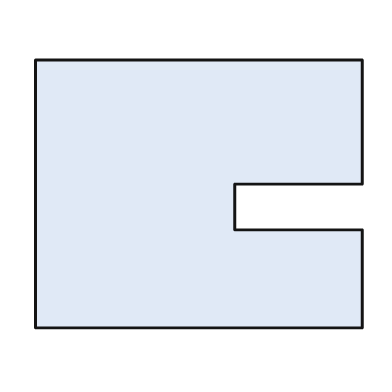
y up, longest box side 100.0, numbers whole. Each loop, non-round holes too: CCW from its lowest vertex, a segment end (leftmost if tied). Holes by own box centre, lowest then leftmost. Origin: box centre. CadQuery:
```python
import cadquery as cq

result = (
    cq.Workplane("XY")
    .moveTo(-50.0, -41.0)
    .lineTo(50.0, -41.0)
    .lineTo(50.0, -11.0)
    .lineTo(11.0, -11.0)
    .lineTo(11.0, 3.0)
    .lineTo(50.0, 3.0)
    .lineTo(50.0, 41.0)
    .lineTo(-50.0, 41.0)
    .close()
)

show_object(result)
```